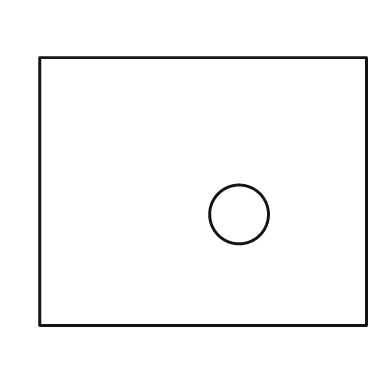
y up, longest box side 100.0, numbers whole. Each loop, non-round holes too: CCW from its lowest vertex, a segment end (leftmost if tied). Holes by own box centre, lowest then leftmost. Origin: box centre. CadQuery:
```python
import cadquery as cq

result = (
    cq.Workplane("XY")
    .moveTo(-50.0, -41.0)
    .lineTo(50.0, -41.0)
    .lineTo(50.0, 41.0)
    .lineTo(-50.0, 41.0)
    .close()
    .moveTo(11.0, -7.0)
    .circle(9.0)
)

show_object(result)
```